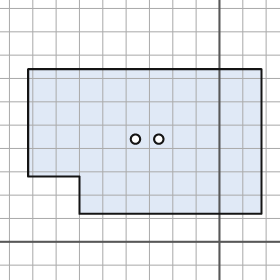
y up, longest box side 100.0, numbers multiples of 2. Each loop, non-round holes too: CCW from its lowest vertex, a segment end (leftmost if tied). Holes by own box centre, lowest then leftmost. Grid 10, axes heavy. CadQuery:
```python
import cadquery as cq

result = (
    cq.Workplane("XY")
    .moveTo(-60.0, 12.0)
    .lineTo(18.0, 12.0)
    .lineTo(18.0, 74.0)
    .lineTo(-82.0, 74.0)
    .lineTo(-82.0, 28.0)
    .lineTo(-60.0, 28.0)
    .close()
    .moveTo(-36.0, 44.0)
    .circle(2.0)
    .moveTo(-26.0, 44.0)
    .circle(2.0)
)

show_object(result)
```